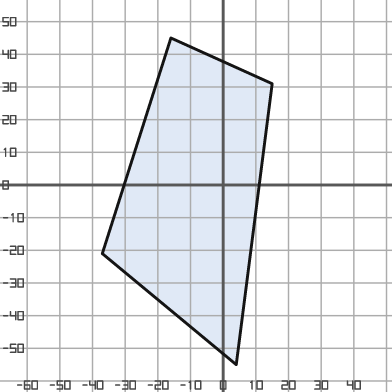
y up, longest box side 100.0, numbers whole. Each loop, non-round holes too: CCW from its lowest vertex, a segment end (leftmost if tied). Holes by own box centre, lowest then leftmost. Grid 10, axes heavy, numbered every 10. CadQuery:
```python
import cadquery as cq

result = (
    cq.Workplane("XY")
    .moveTo(4.0, -55.0)
    .lineTo(15.0, 31.0)
    .lineTo(-16.0, 45.0)
    .lineTo(-37.0, -21.0)
    .close()
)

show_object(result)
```